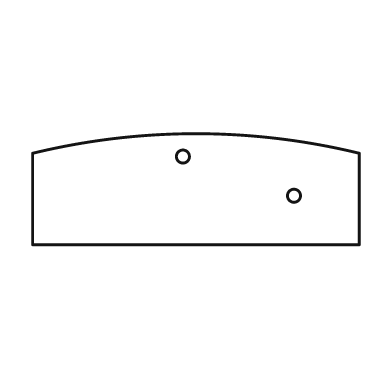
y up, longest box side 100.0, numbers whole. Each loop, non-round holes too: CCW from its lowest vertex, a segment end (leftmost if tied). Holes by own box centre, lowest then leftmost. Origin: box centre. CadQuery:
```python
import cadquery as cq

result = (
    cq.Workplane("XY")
    .moveTo(-50.0, -17.0)
    .lineTo(50.0, -17.0)
    .lineTo(50.0, 11.0)
    .threePointArc((0.0, 17.0), (-50.0, 11.0))
    .close()
    .moveTo(30.0, -2.0)
    .circle(2.0)
    .moveTo(-4.0, 10.0)
    .circle(2.0)
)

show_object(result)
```